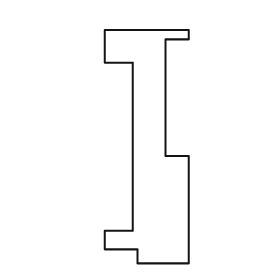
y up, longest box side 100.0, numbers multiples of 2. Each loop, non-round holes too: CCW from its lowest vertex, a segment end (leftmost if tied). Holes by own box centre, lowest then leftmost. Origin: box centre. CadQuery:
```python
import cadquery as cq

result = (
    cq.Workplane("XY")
    .moveTo(-4.0, -50.0)
    .lineTo(18.0, -50.0)
    .lineTo(18.0, -4.0)
    .lineTo(8.0, -4.0)
    .lineTo(8.0, 46.0)
    .lineTo(18.0, 46.0)
    .lineTo(18.0, 50.0)
    .lineTo(-18.0, 50.0)
    .lineTo(-18.0, 36.0)
    .lineTo(-6.0, 36.0)
    .lineTo(-6.0, -36.0)
    .lineTo(-18.0, -36.0)
    .lineTo(-18.0, -44.0)
    .lineTo(-4.0, -44.0)
    .close()
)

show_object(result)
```